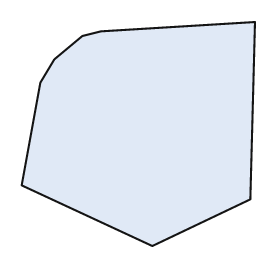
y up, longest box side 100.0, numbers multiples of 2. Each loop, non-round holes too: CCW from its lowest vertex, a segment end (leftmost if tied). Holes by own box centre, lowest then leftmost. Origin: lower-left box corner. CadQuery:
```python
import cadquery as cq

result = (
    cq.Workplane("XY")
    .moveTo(56.0, 0.0)
    .lineTo(98.0, 20.0)
    .lineTo(100.0, 96.0)
    .lineTo(34.0, 92.0)
    .lineTo(26.0, 90.0)
    .lineTo(14.0, 80.0)
    .lineTo(8.0, 70.0)
    .lineTo(0.0, 26.0)
    .close()
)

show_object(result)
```